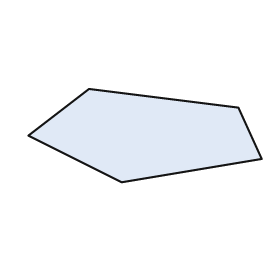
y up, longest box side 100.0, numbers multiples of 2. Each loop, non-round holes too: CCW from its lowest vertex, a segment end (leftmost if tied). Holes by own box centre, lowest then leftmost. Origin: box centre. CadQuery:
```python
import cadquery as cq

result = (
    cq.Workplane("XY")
    .moveTo(-10.0, -20.0)
    .lineTo(50.0, -10.0)
    .lineTo(40.0, 12.0)
    .lineTo(-24.0, 20.0)
    .lineTo(-50.0, 0.0)
    .close()
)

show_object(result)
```